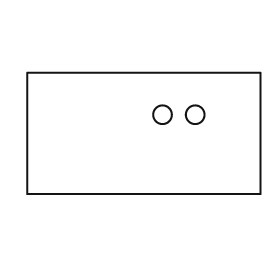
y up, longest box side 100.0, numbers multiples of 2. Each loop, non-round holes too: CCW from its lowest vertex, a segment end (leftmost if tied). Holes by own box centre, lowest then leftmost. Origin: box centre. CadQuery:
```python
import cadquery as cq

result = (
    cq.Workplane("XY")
    .moveTo(-50.0, -26.0)
    .lineTo(50.0, -26.0)
    .lineTo(50.0, 26.0)
    .lineTo(-50.0, 26.0)
    .close()
    .moveTo(8.0, 8.0)
    .circle(4.0)
    .moveTo(22.0, 8.0)
    .circle(4.0)
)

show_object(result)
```